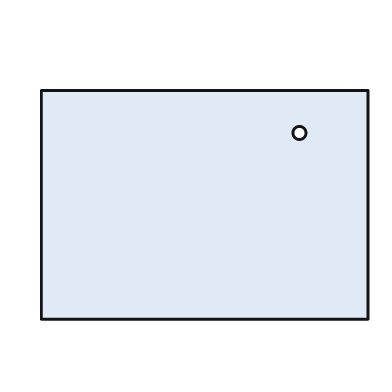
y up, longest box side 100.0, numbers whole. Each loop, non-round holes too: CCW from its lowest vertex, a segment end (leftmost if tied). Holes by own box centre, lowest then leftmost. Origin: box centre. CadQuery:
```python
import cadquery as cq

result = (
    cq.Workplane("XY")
    .moveTo(-50.0, -35.0)
    .lineTo(50.0, -35.0)
    .lineTo(50.0, 35.0)
    .lineTo(-50.0, 35.0)
    .close()
    .moveTo(29.0, 22.0)
    .circle(2.0)
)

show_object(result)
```